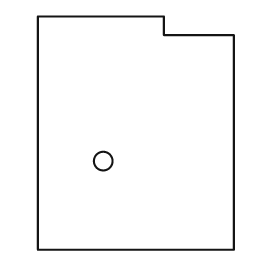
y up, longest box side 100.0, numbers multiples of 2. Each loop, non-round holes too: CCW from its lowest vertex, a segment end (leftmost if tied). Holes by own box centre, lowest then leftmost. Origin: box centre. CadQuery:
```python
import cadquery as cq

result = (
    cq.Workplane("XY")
    .moveTo(-42.0, -50.0)
    .lineTo(42.0, -50.0)
    .lineTo(42.0, 42.0)
    .lineTo(12.0, 42.0)
    .lineTo(12.0, 50.0)
    .lineTo(-42.0, 50.0)
    .close()
    .moveTo(-14.0, -12.0)
    .circle(4.0)
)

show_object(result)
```